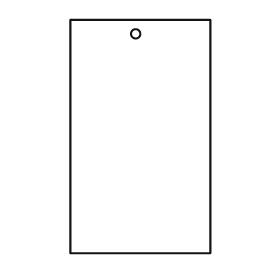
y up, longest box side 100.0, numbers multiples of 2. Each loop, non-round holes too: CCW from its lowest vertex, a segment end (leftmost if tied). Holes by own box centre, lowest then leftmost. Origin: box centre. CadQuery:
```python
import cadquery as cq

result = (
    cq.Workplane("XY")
    .moveTo(-30.0, -50.0)
    .lineTo(30.0, -50.0)
    .lineTo(30.0, 50.0)
    .lineTo(-30.0, 50.0)
    .close()
    .moveTo(-2.0, 44.0)
    .circle(2.0)
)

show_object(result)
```